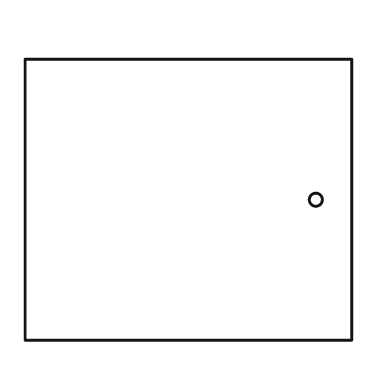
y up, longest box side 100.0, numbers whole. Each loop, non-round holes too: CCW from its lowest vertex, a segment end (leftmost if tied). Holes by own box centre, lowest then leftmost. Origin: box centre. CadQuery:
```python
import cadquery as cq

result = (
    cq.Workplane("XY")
    .moveTo(-50.0, -43.0)
    .lineTo(50.0, -43.0)
    .lineTo(50.0, 43.0)
    .lineTo(-50.0, 43.0)
    .close()
    .moveTo(39.0, 0.0)
    .circle(2.0)
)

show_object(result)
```